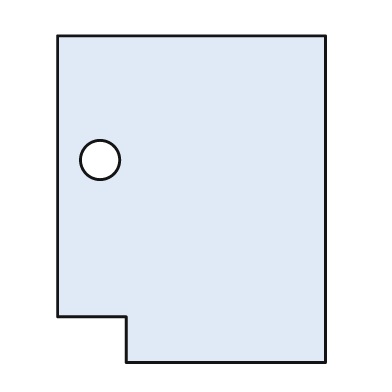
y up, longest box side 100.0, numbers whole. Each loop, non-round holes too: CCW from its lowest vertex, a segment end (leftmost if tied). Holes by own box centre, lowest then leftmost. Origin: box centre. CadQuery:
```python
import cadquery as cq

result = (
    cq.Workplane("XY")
    .moveTo(-20.0, -50.0)
    .lineTo(41.0, -50.0)
    .lineTo(41.0, 50.0)
    .lineTo(-41.0, 50.0)
    .lineTo(-41.0, -36.0)
    .lineTo(-20.0, -36.0)
    .close()
    .moveTo(-28.0, 12.0)
    .circle(6.0)
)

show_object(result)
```